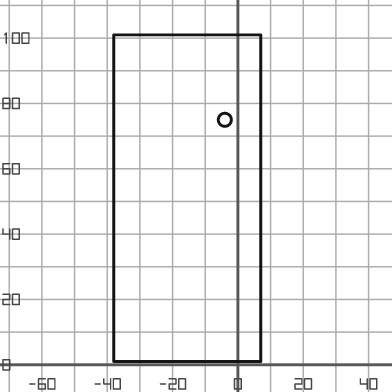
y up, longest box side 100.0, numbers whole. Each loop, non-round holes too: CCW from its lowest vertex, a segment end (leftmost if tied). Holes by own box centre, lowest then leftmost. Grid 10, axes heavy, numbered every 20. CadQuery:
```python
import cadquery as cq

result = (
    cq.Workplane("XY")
    .moveTo(-38.0, 1.0)
    .lineTo(7.0, 1.0)
    .lineTo(7.0, 101.0)
    .lineTo(-38.0, 101.0)
    .close()
    .moveTo(-4.0, 75.0)
    .circle(2.0)
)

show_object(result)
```